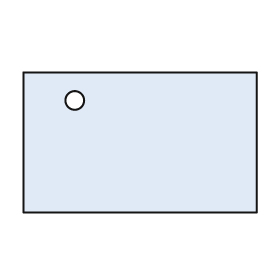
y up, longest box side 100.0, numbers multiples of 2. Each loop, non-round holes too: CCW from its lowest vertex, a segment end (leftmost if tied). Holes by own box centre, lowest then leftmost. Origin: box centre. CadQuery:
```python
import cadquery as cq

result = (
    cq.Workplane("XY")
    .moveTo(-50.0, -30.0)
    .lineTo(50.0, -30.0)
    .lineTo(50.0, 30.0)
    .lineTo(-50.0, 30.0)
    .close()
    .moveTo(-28.0, 18.0)
    .circle(4.0)
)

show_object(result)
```